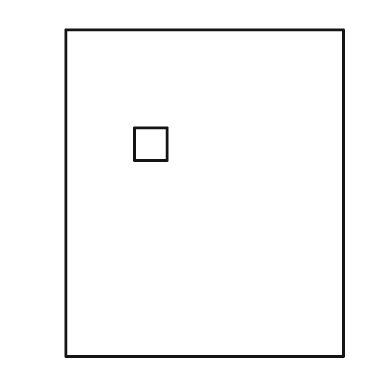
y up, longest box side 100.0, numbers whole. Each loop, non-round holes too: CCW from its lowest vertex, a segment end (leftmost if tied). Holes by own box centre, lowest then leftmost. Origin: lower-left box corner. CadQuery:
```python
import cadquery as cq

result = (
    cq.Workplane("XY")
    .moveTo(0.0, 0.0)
    .lineTo(85.0, 0.0)
    .lineTo(85.0, 100.0)
    .lineTo(0.0, 100.0)
    .close()
    .moveTo(21.0, 60.0)
    .lineTo(31.0, 60.0)
    .lineTo(31.0, 70.0)
    .lineTo(21.0, 70.0)
    .close()
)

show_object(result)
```